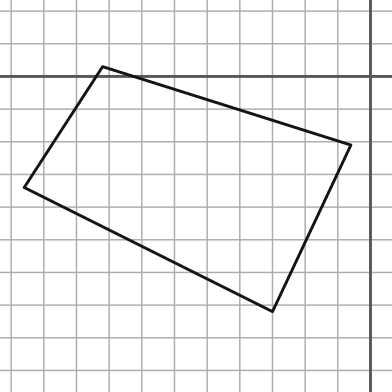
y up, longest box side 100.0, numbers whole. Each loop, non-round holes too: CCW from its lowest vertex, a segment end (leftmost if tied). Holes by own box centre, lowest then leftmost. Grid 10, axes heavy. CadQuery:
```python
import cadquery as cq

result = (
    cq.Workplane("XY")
    .moveTo(-30.0, -72.0)
    .lineTo(-6.0, -21.0)
    .lineTo(-82.0, 3.0)
    .lineTo(-106.0, -34.0)
    .close()
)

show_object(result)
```